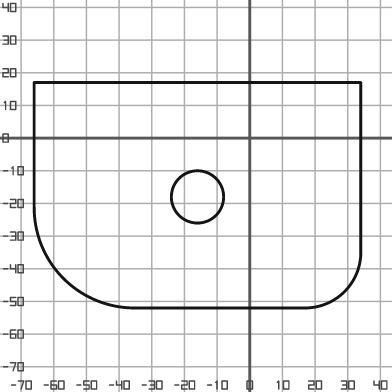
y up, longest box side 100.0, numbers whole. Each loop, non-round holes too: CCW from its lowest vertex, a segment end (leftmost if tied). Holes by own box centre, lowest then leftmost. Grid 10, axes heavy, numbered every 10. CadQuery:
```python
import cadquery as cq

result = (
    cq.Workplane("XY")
    .moveTo(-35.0, -52.0)
    .lineTo(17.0, -52.0)
    .threePointArc((29.0, -47.0), (34.0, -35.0))
    .lineTo(34.0, 17.0)
    .lineTo(-66.0, 17.0)
    .lineTo(-66.0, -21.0)
    .threePointArc((-57.0, -43.0), (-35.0, -52.0))
    .close()
    .moveTo(-16.0, -18.0)
    .circle(8.0)
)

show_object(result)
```